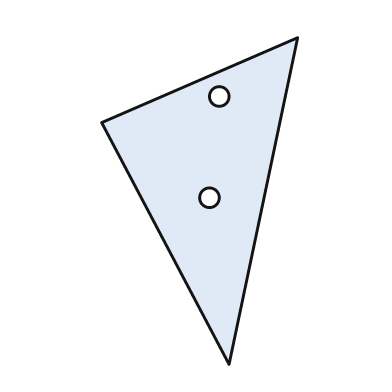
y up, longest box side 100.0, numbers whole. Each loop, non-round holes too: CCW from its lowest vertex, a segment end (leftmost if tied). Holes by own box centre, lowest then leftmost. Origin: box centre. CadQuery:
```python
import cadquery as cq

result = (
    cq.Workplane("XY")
    .moveTo(9.0, -50.0)
    .lineTo(30.0, 50.0)
    .lineTo(-30.0, 24.0)
    .close()
    .moveTo(3.0, 1.0)
    .circle(3.0)
    .moveTo(6.0, 32.0)
    .circle(3.0)
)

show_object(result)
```